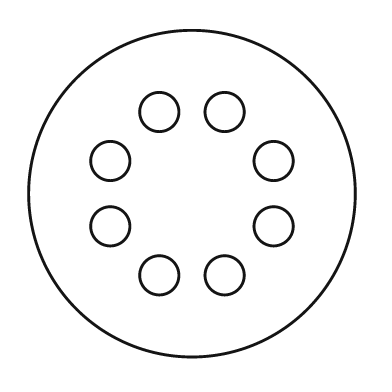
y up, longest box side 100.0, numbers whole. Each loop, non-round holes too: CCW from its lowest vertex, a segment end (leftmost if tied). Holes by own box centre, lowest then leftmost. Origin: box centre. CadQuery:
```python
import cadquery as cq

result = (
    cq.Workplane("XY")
    .moveTo(0.0, 0.0)
    .circle(50.0)
    .moveTo(-10.0, -25.0)
    .circle(6.0)
    .moveTo(10.0, -25.0)
    .circle(6.0)
    .moveTo(-25.0, -10.0)
    .circle(6.0)
    .moveTo(25.0, -10.0)
    .circle(6.0)
    .moveTo(-25.0, 10.0)
    .circle(6.0)
    .moveTo(25.0, 10.0)
    .circle(6.0)
    .moveTo(-10.0, 25.0)
    .circle(6.0)
    .moveTo(10.0, 25.0)
    .circle(6.0)
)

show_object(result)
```